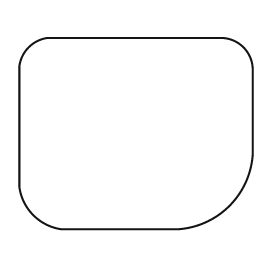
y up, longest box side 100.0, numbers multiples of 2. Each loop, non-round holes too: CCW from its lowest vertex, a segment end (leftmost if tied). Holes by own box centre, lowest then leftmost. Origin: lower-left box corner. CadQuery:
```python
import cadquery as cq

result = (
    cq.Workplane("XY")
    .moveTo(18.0, 0.0)
    .lineTo(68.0, 0.0)
    .threePointArc((90.0, 10.0), (100.0, 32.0))
    .lineTo(100.0, 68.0)
    .threePointArc((96.0, 78.0), (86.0, 82.0))
    .lineTo(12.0, 82.0)
    .threePointArc((4.0, 78.0), (0.0, 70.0))
    .lineTo(0.0, 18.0)
    .threePointArc((6.0, 6.0), (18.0, 0.0))
    .close()
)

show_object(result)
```